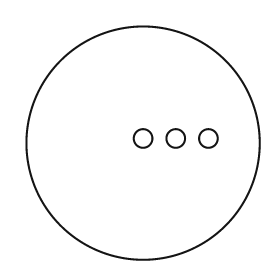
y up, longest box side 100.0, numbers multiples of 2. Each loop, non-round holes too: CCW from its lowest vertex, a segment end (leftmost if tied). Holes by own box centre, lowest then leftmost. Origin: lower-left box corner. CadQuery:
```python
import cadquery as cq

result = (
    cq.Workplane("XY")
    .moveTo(50.0, 50.0)
    .circle(50.0)
    .moveTo(50.0, 52.0)
    .circle(4.0)
    .moveTo(64.0, 52.0)
    .circle(4.0)
    .moveTo(78.0, 52.0)
    .circle(4.0)
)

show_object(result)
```